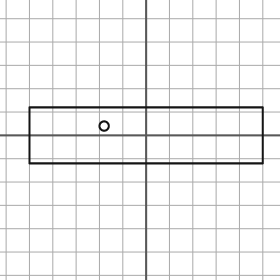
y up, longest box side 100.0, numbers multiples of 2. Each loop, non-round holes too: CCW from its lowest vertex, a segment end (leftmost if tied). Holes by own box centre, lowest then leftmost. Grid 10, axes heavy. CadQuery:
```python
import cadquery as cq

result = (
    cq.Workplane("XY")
    .moveTo(-50.0, -12.0)
    .lineTo(50.0, -12.0)
    .lineTo(50.0, 12.0)
    .lineTo(-50.0, 12.0)
    .close()
    .moveTo(-18.0, 4.0)
    .circle(2.0)
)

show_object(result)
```